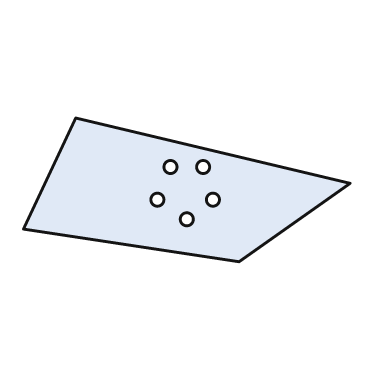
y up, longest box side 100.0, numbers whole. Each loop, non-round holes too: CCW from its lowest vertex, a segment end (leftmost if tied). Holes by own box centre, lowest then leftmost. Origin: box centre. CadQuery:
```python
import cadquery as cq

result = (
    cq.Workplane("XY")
    .moveTo(16.0, -22.0)
    .lineTo(50.0, 2.0)
    .lineTo(-34.0, 22.0)
    .lineTo(-50.0, -12.0)
    .close()
    .moveTo(0.0, -9.0)
    .circle(2.0)
    .moveTo(-9.0, -3.0)
    .circle(2.0)
    .moveTo(8.0, -3.0)
    .circle(2.0)
    .moveTo(-5.0, 7.0)
    .circle(2.0)
    .moveTo(5.0, 7.0)
    .circle(2.0)
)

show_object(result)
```